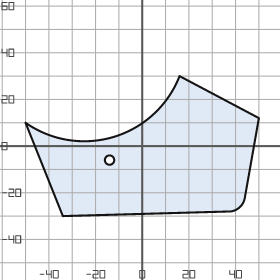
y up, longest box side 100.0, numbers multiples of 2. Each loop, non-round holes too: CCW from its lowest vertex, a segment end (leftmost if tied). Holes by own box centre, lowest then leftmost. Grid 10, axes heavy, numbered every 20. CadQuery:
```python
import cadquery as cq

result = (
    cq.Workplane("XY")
    .moveTo(-34.0, -30.0)
    .lineTo(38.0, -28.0)
    .threePointArc((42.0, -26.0), (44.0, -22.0))
    .lineTo(50.0, 12.0)
    .lineTo(16.0, 30.0)
    .threePointArc((-12.0, 4.0), (-50.0, 10.0))
    .close()
    .moveTo(-14.0, -6.0)
    .circle(2.0)
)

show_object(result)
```